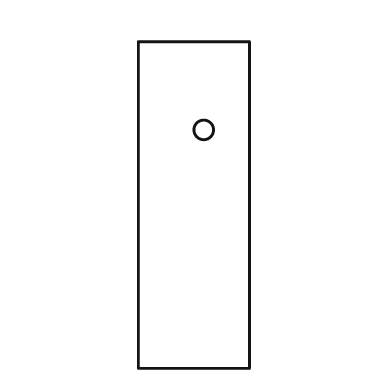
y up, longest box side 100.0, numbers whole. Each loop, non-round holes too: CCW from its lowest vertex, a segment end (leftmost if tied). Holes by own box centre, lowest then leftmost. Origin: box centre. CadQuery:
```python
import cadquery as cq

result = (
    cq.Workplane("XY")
    .moveTo(-17.0, -50.0)
    .lineTo(17.0, -50.0)
    .lineTo(17.0, 50.0)
    .lineTo(-17.0, 50.0)
    .close()
    .moveTo(3.0, 23.0)
    .circle(3.0)
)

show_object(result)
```